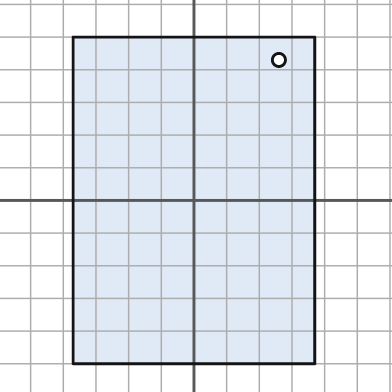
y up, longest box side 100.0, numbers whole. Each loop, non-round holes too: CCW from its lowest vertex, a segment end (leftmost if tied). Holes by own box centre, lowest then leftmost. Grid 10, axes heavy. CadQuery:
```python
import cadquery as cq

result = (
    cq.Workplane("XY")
    .moveTo(-37.0, -50.0)
    .lineTo(37.0, -50.0)
    .lineTo(37.0, 50.0)
    .lineTo(-37.0, 50.0)
    .close()
    .moveTo(26.0, 43.0)
    .circle(2.0)
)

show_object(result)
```